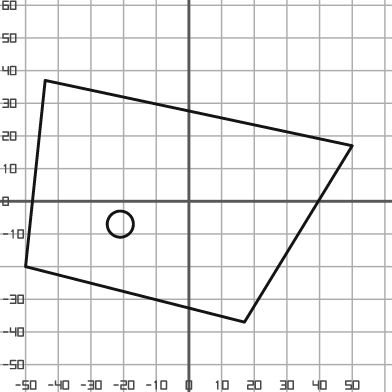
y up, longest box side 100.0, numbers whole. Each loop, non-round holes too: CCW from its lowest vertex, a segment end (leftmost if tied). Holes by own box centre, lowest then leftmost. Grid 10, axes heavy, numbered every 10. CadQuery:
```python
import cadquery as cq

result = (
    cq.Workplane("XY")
    .moveTo(17.0, -37.0)
    .lineTo(50.0, 17.0)
    .lineTo(-44.0, 37.0)
    .lineTo(-50.0, -20.0)
    .close()
    .moveTo(-21.0, -7.0)
    .circle(4.0)
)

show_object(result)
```